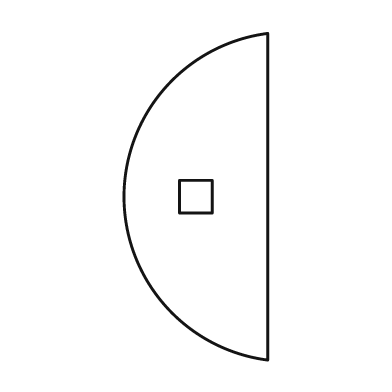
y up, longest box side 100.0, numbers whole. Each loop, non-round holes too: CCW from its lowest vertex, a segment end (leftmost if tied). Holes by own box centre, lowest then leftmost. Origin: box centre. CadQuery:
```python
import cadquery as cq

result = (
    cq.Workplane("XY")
    .moveTo(22.0, -50.0)
    .lineTo(22.0, 50.0)
    .threePointArc((-22.0, 0.0), (22.0, -50.0))
    .close()
    .moveTo(-5.0, -5.0)
    .lineTo(5.0, -5.0)
    .lineTo(5.0, 5.0)
    .lineTo(-5.0, 5.0)
    .close()
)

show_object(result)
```